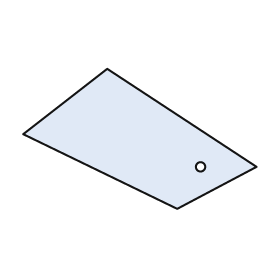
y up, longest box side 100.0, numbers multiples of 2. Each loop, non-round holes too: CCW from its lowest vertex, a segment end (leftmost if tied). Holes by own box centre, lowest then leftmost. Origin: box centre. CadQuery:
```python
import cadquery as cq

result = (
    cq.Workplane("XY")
    .moveTo(16.0, -30.0)
    .lineTo(50.0, -12.0)
    .lineTo(-14.0, 30.0)
    .lineTo(-50.0, 2.0)
    .close()
    .moveTo(26.0, -12.0)
    .circle(2.0)
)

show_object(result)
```